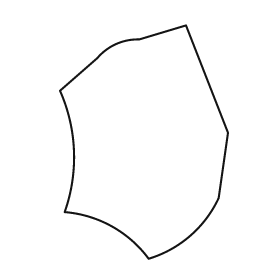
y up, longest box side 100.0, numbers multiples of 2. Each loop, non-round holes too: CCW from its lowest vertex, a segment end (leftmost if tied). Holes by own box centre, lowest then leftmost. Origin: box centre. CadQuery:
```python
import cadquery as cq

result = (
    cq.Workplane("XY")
    .moveTo(2.0, -50.0)
    .threePointArc((20.0, -40.0), (32.0, -24.0))
    .lineTo(36.0, 4.0)
    .lineTo(18.0, 50.0)
    .lineTo(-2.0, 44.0)
    .threePointArc((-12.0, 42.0), (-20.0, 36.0))
    .lineTo(-36.0, 22.0)
    .threePointArc((-30.0, -4.0), (-34.0, -30.0))
    .threePointArc((-14.0, -36.0), (2.0, -50.0))
    .close()
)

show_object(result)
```